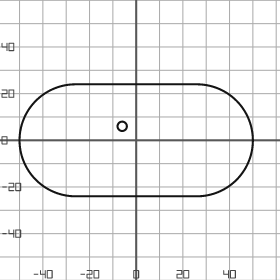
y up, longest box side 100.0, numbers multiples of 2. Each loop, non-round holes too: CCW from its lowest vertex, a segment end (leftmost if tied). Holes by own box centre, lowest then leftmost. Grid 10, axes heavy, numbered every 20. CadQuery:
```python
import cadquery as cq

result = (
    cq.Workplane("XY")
    .moveTo(-26.0, -24.0)
    .lineTo(26.0, -24.0)
    .threePointArc((50.0, 0.0), (26.0, 24.0))
    .lineTo(-26.0, 24.0)
    .threePointArc((-50.0, 0.0), (-26.0, -24.0))
    .close()
    .moveTo(-6.0, 6.0)
    .circle(2.0)
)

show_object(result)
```